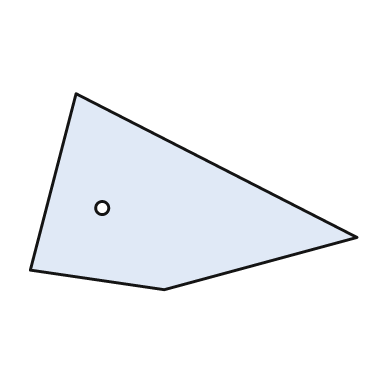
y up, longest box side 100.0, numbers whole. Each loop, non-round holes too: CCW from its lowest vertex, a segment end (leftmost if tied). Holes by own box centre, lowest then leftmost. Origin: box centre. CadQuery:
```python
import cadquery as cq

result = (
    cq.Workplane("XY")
    .moveTo(-9.0, -30.0)
    .lineTo(50.0, -14.0)
    .lineTo(-36.0, 30.0)
    .lineTo(-50.0, -24.0)
    .close()
    .moveTo(-28.0, -5.0)
    .circle(2.0)
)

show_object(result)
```